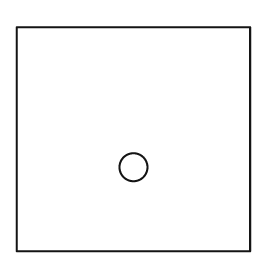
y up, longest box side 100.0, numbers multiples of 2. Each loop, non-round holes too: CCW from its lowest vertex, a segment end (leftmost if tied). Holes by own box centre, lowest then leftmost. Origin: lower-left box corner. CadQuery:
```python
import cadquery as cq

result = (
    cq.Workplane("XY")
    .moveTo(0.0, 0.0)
    .lineTo(100.0, 0.0)
    .lineTo(100.0, 96.0)
    .lineTo(0.0, 96.0)
    .close()
    .moveTo(50.0, 36.0)
    .circle(6.0)
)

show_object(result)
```